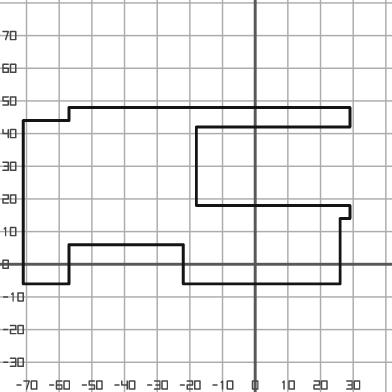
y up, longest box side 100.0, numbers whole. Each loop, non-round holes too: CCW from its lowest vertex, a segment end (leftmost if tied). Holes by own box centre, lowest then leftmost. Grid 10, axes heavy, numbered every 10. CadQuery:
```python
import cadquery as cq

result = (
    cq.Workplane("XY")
    .moveTo(-71.0, -6.0)
    .lineTo(-57.0, -6.0)
    .lineTo(-57.0, 6.0)
    .lineTo(-22.0, 6.0)
    .lineTo(-22.0, -6.0)
    .lineTo(26.0, -6.0)
    .lineTo(26.0, 14.0)
    .lineTo(29.0, 14.0)
    .lineTo(29.0, 18.0)
    .lineTo(-18.0, 18.0)
    .lineTo(-18.0, 42.0)
    .lineTo(29.0, 42.0)
    .lineTo(29.0, 48.0)
    .lineTo(-57.0, 48.0)
    .lineTo(-57.0, 44.0)
    .lineTo(-71.0, 44.0)
    .close()
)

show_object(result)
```